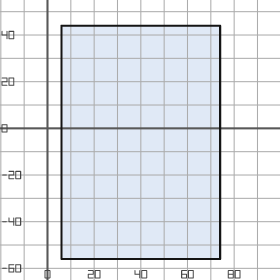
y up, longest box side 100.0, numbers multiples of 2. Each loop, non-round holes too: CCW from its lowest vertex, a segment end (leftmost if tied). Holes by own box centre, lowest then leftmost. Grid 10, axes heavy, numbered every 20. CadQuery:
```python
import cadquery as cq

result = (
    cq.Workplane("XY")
    .moveTo(6.0, -56.0)
    .lineTo(74.0, -56.0)
    .lineTo(74.0, 44.0)
    .lineTo(6.0, 44.0)
    .close()
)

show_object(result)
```